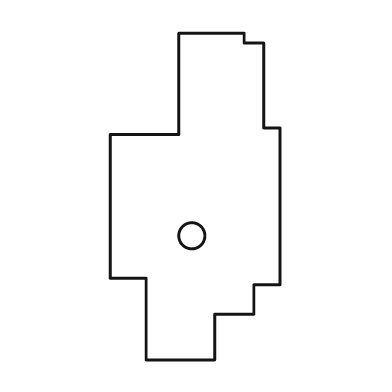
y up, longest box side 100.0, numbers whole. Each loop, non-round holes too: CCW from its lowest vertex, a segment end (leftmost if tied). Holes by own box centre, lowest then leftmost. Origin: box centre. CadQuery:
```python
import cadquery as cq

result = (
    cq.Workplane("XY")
    .moveTo(-15.0, -50.0)
    .lineTo(6.0, -50.0)
    .lineTo(6.0, -36.0)
    .lineTo(18.0, -36.0)
    .lineTo(18.0, -27.0)
    .lineTo(26.0, -27.0)
    .lineTo(26.0, 21.0)
    .lineTo(21.0, 21.0)
    .lineTo(21.0, 47.0)
    .lineTo(15.0, 47.0)
    .lineTo(15.0, 50.0)
    .lineTo(-5.0, 50.0)
    .lineTo(-5.0, 19.0)
    .lineTo(-26.0, 19.0)
    .lineTo(-26.0, -25.0)
    .lineTo(-15.0, -25.0)
    .close()
    .moveTo(-1.0, -12.0)
    .circle(4.0)
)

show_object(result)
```